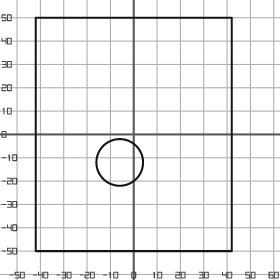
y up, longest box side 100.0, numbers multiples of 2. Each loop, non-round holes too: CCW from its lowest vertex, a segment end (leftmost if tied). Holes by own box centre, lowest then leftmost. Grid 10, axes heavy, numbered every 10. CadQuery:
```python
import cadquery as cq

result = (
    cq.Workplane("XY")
    .moveTo(-42.0, -50.0)
    .lineTo(42.0, -50.0)
    .lineTo(42.0, 50.0)
    .lineTo(-42.0, 50.0)
    .close()
    .moveTo(-6.0, -12.0)
    .circle(10.0)
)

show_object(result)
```